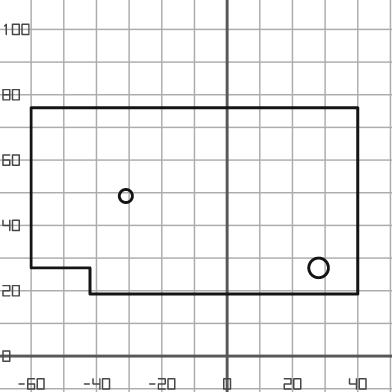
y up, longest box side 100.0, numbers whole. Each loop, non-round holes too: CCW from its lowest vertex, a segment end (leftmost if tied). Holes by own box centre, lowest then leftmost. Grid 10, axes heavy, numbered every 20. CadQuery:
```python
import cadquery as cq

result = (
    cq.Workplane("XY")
    .moveTo(-42.0, 19.0)
    .lineTo(40.0, 19.0)
    .lineTo(40.0, 76.0)
    .lineTo(-60.0, 76.0)
    .lineTo(-60.0, 27.0)
    .lineTo(-42.0, 27.0)
    .close()
    .moveTo(28.0, 27.0)
    .circle(3.0)
    .moveTo(-31.0, 49.0)
    .circle(2.0)
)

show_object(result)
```